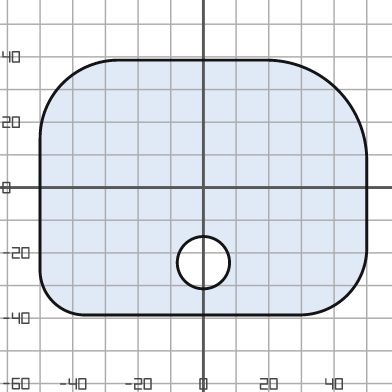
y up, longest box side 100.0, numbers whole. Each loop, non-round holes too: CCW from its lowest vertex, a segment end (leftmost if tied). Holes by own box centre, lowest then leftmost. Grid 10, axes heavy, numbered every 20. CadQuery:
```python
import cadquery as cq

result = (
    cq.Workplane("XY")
    .moveTo(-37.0, -39.0)
    .lineTo(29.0, -39.0)
    .threePointArc((44.0, -33.0), (50.0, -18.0))
    .lineTo(50.0, 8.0)
    .threePointArc((41.0, 30.0), (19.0, 39.0))
    .lineTo(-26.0, 39.0)
    .threePointArc((-43.0, 32.0), (-50.0, 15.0))
    .lineTo(-50.0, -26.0)
    .threePointArc((-46.0, -35.0), (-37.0, -39.0))
    .close()
    .moveTo(0.0, -23.0)
    .circle(8.0)
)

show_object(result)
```